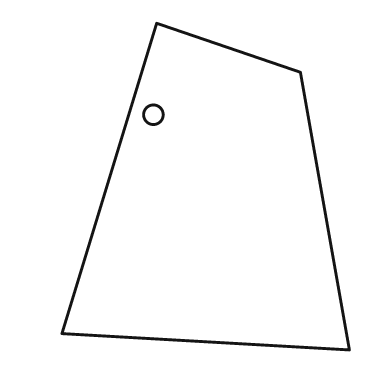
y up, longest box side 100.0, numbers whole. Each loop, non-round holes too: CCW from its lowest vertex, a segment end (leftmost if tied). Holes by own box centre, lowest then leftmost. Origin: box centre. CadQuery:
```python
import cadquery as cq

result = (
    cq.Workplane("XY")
    .moveTo(44.0, -50.0)
    .lineTo(29.0, 35.0)
    .lineTo(-15.0, 50.0)
    .lineTo(-44.0, -45.0)
    .close()
    .moveTo(-16.0, 22.0)
    .circle(3.0)
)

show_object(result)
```